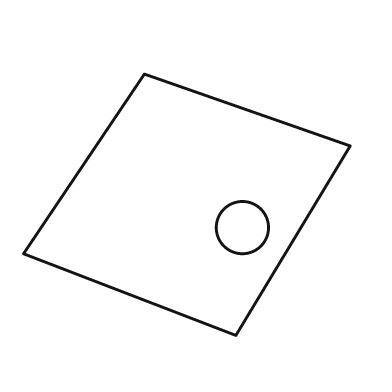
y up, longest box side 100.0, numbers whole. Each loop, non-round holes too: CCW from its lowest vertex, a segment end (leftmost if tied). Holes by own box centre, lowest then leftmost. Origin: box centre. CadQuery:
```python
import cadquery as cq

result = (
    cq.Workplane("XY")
    .moveTo(15.0, -40.0)
    .lineTo(50.0, 18.0)
    .lineTo(-13.0, 40.0)
    .lineTo(-50.0, -15.0)
    .close()
    .moveTo(17.0, -7.0)
    .circle(8.0)
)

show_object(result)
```